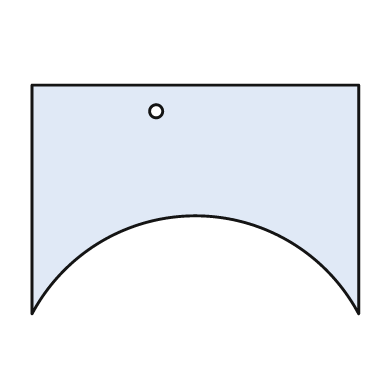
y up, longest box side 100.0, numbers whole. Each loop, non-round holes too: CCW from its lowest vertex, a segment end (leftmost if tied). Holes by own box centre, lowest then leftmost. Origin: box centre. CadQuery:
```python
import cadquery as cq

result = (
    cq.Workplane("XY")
    .moveTo(-50.0, -35.0)
    .threePointArc((0.0, -5.0), (50.0, -35.0))
    .lineTo(50.0, 35.0)
    .lineTo(-50.0, 35.0)
    .close()
    .moveTo(-12.0, 27.0)
    .circle(2.0)
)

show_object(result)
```